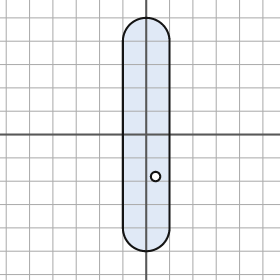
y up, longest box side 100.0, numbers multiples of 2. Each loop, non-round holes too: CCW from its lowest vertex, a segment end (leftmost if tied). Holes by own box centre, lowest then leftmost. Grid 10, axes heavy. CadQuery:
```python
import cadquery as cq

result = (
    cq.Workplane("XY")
    .moveTo(-10.0, -40.0)
    .threePointArc((0.0, -50.0), (10.0, -40.0))
    .lineTo(10.0, 40.0)
    .threePointArc((0.0, 50.0), (-10.0, 40.0))
    .close()
    .moveTo(4.0, -18.0)
    .circle(2.0)
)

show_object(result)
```